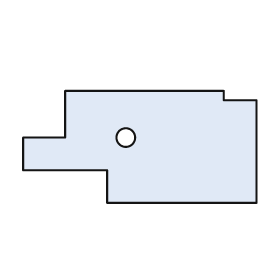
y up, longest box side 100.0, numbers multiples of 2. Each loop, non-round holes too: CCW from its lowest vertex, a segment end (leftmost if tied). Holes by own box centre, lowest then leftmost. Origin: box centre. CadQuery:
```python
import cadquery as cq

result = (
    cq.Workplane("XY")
    .moveTo(-14.0, -24.0)
    .lineTo(50.0, -24.0)
    .lineTo(50.0, 20.0)
    .lineTo(36.0, 20.0)
    .lineTo(36.0, 24.0)
    .lineTo(-32.0, 24.0)
    .lineTo(-32.0, 4.0)
    .lineTo(-50.0, 4.0)
    .lineTo(-50.0, -10.0)
    .lineTo(-14.0, -10.0)
    .close()
    .moveTo(-6.0, 4.0)
    .circle(4.0)
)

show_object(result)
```